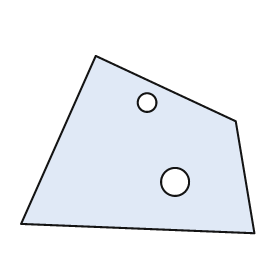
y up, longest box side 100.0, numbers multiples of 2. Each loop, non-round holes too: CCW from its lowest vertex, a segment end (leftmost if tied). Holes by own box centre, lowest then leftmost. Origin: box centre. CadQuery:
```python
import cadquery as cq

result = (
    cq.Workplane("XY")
    .moveTo(50.0, -38.0)
    .lineTo(42.0, 10.0)
    .lineTo(-18.0, 38.0)
    .lineTo(-50.0, -34.0)
    .close()
    .moveTo(16.0, -16.0)
    .circle(6.0)
    .moveTo(4.0, 18.0)
    .circle(4.0)
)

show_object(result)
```